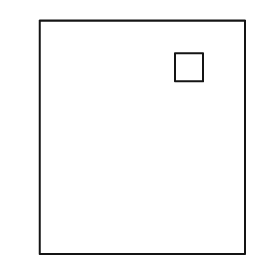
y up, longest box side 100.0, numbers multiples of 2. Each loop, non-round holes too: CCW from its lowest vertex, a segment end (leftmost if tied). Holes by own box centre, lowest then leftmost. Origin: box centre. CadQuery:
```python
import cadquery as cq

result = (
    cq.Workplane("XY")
    .moveTo(-44.0, -50.0)
    .lineTo(44.0, -50.0)
    .lineTo(44.0, 50.0)
    .lineTo(-44.0, 50.0)
    .close()
    .moveTo(14.0, 24.0)
    .lineTo(26.0, 24.0)
    .lineTo(26.0, 36.0)
    .lineTo(14.0, 36.0)
    .close()
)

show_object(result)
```